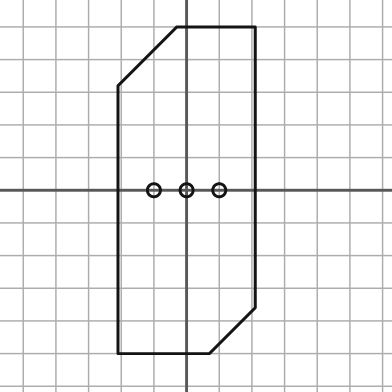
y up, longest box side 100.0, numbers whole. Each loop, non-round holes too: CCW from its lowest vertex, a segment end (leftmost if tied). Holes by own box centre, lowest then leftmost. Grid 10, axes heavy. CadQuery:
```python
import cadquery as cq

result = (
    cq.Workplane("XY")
    .moveTo(-21.0, -50.0)
    .lineTo(7.0, -50.0)
    .lineTo(21.0, -36.0)
    .lineTo(21.0, 50.0)
    .lineTo(-3.0, 50.0)
    .lineTo(-21.0, 32.0)
    .close()
    .moveTo(-10.0, 0.0)
    .circle(2.0)
    .moveTo(0.0, 0.0)
    .circle(2.0)
    .moveTo(10.0, 0.0)
    .circle(2.0)
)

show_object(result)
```